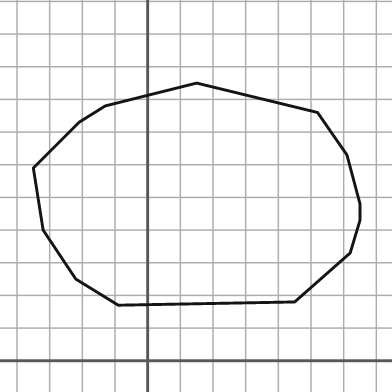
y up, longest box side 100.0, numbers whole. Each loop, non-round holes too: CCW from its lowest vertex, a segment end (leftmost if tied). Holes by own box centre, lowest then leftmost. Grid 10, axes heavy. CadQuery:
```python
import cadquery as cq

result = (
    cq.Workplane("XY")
    .moveTo(-9.0, 17.0)
    .lineTo(45.0, 18.0)
    .lineTo(62.0, 33.0)
    .lineTo(65.0, 43.0)
    .lineTo(65.0, 48.0)
    .lineTo(61.0, 63.0)
    .lineTo(52.0, 76.0)
    .lineTo(15.0, 85.0)
    .lineTo(-13.0, 78.0)
    .lineTo(-21.0, 73.0)
    .lineTo(-35.0, 59.0)
    .lineTo(-32.0, 40.0)
    .lineTo(-22.0, 25.0)
    .close()
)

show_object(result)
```